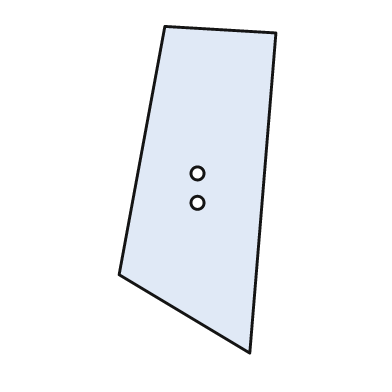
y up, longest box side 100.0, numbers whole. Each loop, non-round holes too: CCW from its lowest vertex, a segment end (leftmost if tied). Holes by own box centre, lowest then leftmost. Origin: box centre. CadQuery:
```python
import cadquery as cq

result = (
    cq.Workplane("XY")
    .moveTo(16.0, -50.0)
    .lineTo(24.0, 48.0)
    .lineTo(-10.0, 50.0)
    .lineTo(-24.0, -26.0)
    .close()
    .moveTo(0.0, -4.0)
    .circle(2.0)
    .moveTo(0.0, 5.0)
    .circle(2.0)
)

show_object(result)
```